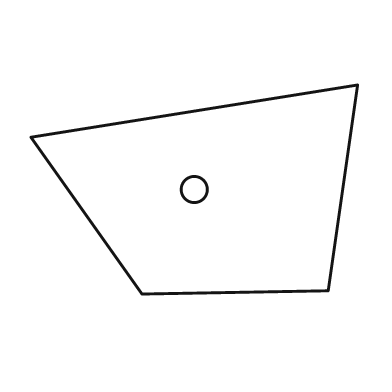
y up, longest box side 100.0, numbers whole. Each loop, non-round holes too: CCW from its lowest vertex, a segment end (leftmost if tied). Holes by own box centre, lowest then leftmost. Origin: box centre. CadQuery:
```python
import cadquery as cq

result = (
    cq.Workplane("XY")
    .moveTo(-16.0, -32.0)
    .lineTo(41.0, -31.0)
    .lineTo(50.0, 32.0)
    .lineTo(-50.0, 16.0)
    .close()
    .moveTo(0.0, 0.0)
    .circle(4.0)
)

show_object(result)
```